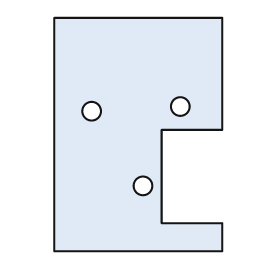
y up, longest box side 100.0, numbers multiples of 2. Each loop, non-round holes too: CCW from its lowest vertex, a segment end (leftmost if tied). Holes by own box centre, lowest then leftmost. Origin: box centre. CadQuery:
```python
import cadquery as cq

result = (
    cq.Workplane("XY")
    .moveTo(-36.0, -50.0)
    .lineTo(36.0, -50.0)
    .lineTo(36.0, -38.0)
    .lineTo(10.0, -38.0)
    .lineTo(10.0, 2.0)
    .lineTo(36.0, 2.0)
    .lineTo(36.0, 50.0)
    .lineTo(-36.0, 50.0)
    .close()
    .moveTo(2.0, -22.0)
    .circle(4.0)
    .moveTo(-20.0, 10.0)
    .circle(4.0)
    .moveTo(18.0, 12.0)
    .circle(4.0)
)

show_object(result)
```